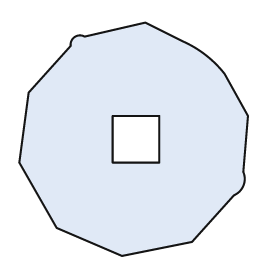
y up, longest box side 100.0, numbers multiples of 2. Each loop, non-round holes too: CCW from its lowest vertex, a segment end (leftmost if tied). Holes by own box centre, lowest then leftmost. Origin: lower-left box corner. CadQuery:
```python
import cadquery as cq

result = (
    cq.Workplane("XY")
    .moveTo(44.0, 0.0)
    .lineTo(74.0, 6.0)
    .lineTo(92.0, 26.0)
    .threePointArc((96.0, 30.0), (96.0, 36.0))
    .lineTo(98.0, 60.0)
    .lineTo(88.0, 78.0)
    .threePointArc((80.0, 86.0), (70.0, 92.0))
    .lineTo(54.0, 100.0)
    .lineTo(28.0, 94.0)
    .threePointArc((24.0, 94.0), (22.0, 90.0))
    .lineTo(4.0, 70.0)
    .lineTo(0.0, 40.0)
    .lineTo(16.0, 12.0)
    .close()
    .moveTo(40.0, 40.0)
    .lineTo(60.0, 40.0)
    .lineTo(60.0, 60.0)
    .lineTo(40.0, 60.0)
    .close()
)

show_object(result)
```